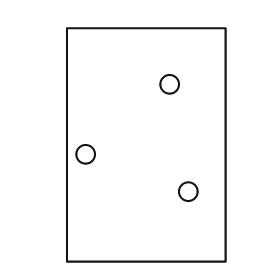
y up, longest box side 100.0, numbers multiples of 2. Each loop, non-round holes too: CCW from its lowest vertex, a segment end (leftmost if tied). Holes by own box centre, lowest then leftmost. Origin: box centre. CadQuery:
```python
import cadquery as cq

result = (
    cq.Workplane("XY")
    .moveTo(-34.0, -50.0)
    .lineTo(34.0, -50.0)
    .lineTo(34.0, 50.0)
    .lineTo(-34.0, 50.0)
    .close()
    .moveTo(18.0, -20.0)
    .circle(4.0)
    .moveTo(-26.0, -4.0)
    .circle(4.0)
    .moveTo(10.0, 26.0)
    .circle(4.0)
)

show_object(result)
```